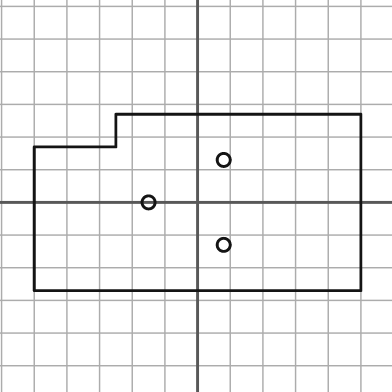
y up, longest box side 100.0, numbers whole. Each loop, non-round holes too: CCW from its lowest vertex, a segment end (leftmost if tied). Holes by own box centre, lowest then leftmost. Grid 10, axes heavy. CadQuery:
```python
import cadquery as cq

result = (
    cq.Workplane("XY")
    .moveTo(-50.0, -27.0)
    .lineTo(50.0, -27.0)
    .lineTo(50.0, 27.0)
    .lineTo(-25.0, 27.0)
    .lineTo(-25.0, 17.0)
    .lineTo(-50.0, 17.0)
    .close()
    .moveTo(8.0, -13.0)
    .circle(2.0)
    .moveTo(-15.0, 0.0)
    .circle(2.0)
    .moveTo(8.0, 13.0)
    .circle(2.0)
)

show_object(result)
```